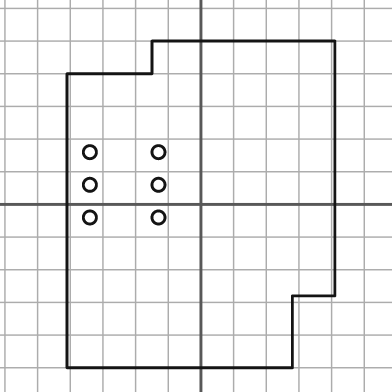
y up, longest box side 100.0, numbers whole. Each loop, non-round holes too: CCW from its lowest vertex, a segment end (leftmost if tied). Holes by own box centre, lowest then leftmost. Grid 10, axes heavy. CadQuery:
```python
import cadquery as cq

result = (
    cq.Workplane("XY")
    .moveTo(-41.0, -50.0)
    .lineTo(28.0, -50.0)
    .lineTo(28.0, -28.0)
    .lineTo(41.0, -28.0)
    .lineTo(41.0, 50.0)
    .lineTo(-15.0, 50.0)
    .lineTo(-15.0, 40.0)
    .lineTo(-41.0, 40.0)
    .close()
    .moveTo(-34.0, -4.0)
    .circle(2.0)
    .moveTo(-13.0, -4.0)
    .circle(2.0)
    .moveTo(-34.0, 6.0)
    .circle(2.0)
    .moveTo(-13.0, 6.0)
    .circle(2.0)
    .moveTo(-34.0, 16.0)
    .circle(2.0)
    .moveTo(-13.0, 16.0)
    .circle(2.0)
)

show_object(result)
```